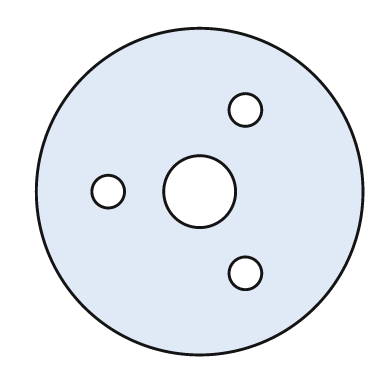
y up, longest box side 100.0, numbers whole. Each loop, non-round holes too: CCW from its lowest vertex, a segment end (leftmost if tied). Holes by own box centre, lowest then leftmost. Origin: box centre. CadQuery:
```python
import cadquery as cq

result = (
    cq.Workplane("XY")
    .moveTo(0.0, 0.0)
    .circle(50.0)
    .moveTo(14.0, -25.0)
    .circle(5.0)
    .moveTo(-28.0, 0.0)
    .circle(5.0)
    .moveTo(0.0, 0.0)
    .circle(11.0)
    .moveTo(14.0, 25.0)
    .circle(5.0)
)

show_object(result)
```